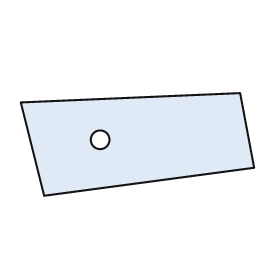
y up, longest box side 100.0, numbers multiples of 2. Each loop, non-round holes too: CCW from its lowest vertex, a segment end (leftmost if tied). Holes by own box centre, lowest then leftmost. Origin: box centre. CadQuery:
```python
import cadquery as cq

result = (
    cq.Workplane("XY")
    .moveTo(-40.0, -22.0)
    .lineTo(50.0, -10.0)
    .lineTo(44.0, 22.0)
    .lineTo(-50.0, 18.0)
    .close()
    .moveTo(-16.0, 2.0)
    .circle(4.0)
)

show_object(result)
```